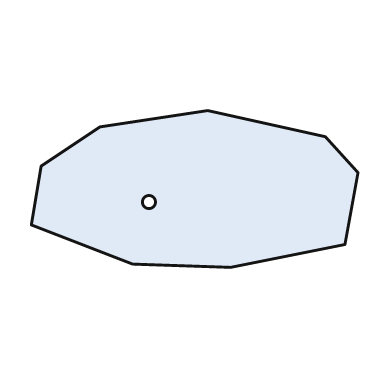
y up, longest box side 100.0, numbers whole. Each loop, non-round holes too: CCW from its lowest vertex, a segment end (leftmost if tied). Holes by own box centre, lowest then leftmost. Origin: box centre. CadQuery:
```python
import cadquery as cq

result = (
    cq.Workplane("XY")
    .moveTo(11.0, -24.0)
    .lineTo(46.0, -17.0)
    .lineTo(50.0, 5.0)
    .lineTo(40.0, 16.0)
    .lineTo(4.0, 24.0)
    .lineTo(-29.0, 19.0)
    .lineTo(-47.0, 7.0)
    .lineTo(-50.0, -11.0)
    .lineTo(-19.0, -23.0)
    .close()
    .moveTo(-14.0, -4.0)
    .circle(2.0)
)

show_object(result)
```